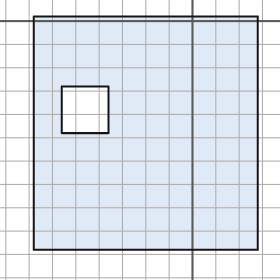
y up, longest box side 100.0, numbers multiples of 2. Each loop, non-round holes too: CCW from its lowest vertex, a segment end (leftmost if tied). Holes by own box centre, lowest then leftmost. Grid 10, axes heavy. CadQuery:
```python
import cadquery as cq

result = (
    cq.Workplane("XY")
    .moveTo(-68.0, -98.0)
    .lineTo(28.0, -98.0)
    .lineTo(28.0, 2.0)
    .lineTo(-68.0, 2.0)
    .close()
    .moveTo(-56.0, -48.0)
    .lineTo(-36.0, -48.0)
    .lineTo(-36.0, -28.0)
    .lineTo(-56.0, -28.0)
    .close()
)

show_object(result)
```